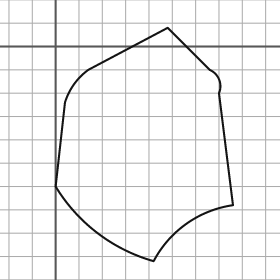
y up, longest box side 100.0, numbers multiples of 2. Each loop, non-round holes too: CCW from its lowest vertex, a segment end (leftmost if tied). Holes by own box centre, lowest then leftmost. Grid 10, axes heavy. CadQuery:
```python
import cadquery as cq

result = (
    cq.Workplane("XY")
    .moveTo(42.0, -92.0)
    .threePointArc((56.0, -76.0), (76.0, -68.0))
    .lineTo(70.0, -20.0)
    .threePointArc((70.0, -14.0), (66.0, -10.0))
    .lineTo(48.0, 8.0)
    .lineTo(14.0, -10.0)
    .threePointArc((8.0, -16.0), (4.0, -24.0))
    .lineTo(0.0, -60.0)
    .threePointArc((18.0, -80.0), (42.0, -92.0))
    .close()
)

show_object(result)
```